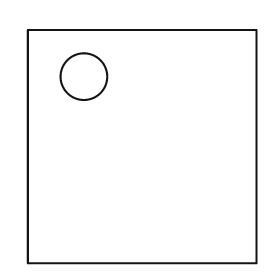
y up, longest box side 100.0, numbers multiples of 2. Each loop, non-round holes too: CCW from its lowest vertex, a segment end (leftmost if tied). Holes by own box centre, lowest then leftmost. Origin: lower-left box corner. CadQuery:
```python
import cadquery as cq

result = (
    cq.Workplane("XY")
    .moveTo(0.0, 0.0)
    .lineTo(98.0, 0.0)
    .lineTo(98.0, 100.0)
    .lineTo(0.0, 100.0)
    .close()
    .moveTo(24.0, 80.0)
    .circle(10.0)
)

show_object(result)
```